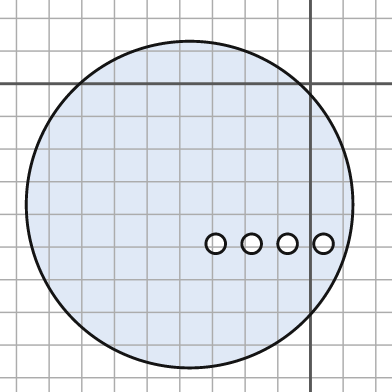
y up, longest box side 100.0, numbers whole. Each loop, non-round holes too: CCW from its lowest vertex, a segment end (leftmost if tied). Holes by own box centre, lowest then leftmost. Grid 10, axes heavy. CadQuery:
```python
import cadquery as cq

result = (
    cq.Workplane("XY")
    .moveTo(-37.0, -37.0)
    .circle(50.0)
    .moveTo(-29.0, -49.0)
    .circle(3.0)
    .moveTo(-18.0, -49.0)
    .circle(3.0)
    .moveTo(-7.0, -49.0)
    .circle(3.0)
    .moveTo(4.0, -49.0)
    .circle(3.0)
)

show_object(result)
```